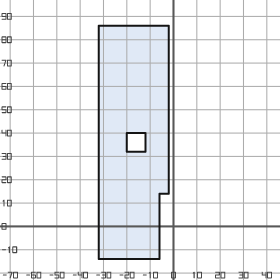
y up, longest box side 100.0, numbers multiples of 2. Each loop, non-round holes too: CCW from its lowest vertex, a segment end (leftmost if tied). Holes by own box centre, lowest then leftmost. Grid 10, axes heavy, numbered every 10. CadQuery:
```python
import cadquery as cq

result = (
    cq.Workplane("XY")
    .moveTo(-32.0, -14.0)
    .lineTo(-6.0, -14.0)
    .lineTo(-6.0, 14.0)
    .lineTo(-2.0, 14.0)
    .lineTo(-2.0, 86.0)
    .lineTo(-32.0, 86.0)
    .close()
    .moveTo(-20.0, 32.0)
    .lineTo(-12.0, 32.0)
    .lineTo(-12.0, 40.0)
    .lineTo(-20.0, 40.0)
    .close()
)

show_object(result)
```